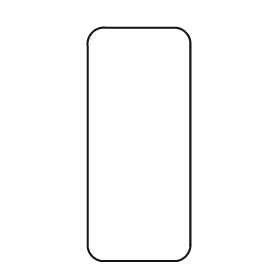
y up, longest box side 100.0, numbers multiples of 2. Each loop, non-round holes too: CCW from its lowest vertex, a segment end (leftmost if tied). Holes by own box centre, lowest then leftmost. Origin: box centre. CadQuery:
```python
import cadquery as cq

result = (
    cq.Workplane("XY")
    .moveTo(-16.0, -50.0)
    .lineTo(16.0, -50.0)
    .threePointArc((20.0, -48.0), (22.0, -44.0))
    .lineTo(22.0, 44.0)
    .threePointArc((20.0, 48.0), (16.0, 50.0))
    .lineTo(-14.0, 50.0)
    .threePointArc((-20.0, 48.0), (-22.0, 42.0))
    .lineTo(-22.0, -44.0)
    .threePointArc((-20.0, -48.0), (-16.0, -50.0))
    .close()
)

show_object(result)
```